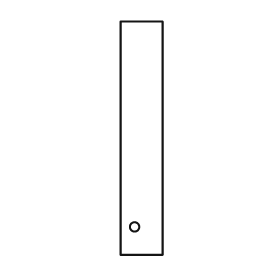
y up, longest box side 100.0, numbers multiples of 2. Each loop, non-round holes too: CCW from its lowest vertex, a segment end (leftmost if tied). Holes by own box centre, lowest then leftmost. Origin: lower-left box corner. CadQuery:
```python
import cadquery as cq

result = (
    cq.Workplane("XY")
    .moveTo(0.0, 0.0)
    .lineTo(18.0, 0.0)
    .lineTo(18.0, 100.0)
    .lineTo(0.0, 100.0)
    .close()
    .moveTo(6.0, 12.0)
    .circle(2.0)
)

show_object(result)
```